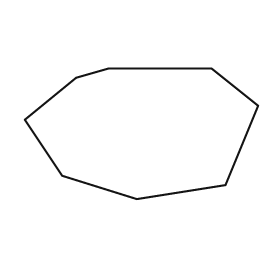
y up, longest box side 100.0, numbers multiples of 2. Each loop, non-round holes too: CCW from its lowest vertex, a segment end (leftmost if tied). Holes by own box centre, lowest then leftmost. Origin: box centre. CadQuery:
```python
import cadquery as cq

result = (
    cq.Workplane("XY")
    .moveTo(-2.0, -28.0)
    .lineTo(36.0, -22.0)
    .lineTo(50.0, 12.0)
    .lineTo(30.0, 28.0)
    .lineTo(-14.0, 28.0)
    .lineTo(-28.0, 24.0)
    .lineTo(-50.0, 6.0)
    .lineTo(-34.0, -18.0)
    .close()
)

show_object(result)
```